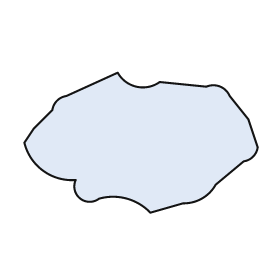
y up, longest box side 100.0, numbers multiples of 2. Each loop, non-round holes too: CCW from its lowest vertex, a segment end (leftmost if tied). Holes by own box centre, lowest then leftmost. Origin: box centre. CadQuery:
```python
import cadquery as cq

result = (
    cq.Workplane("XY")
    .moveTo(4.0, -30.0)
    .lineTo(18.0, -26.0)
    .threePointArc((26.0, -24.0), (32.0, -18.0))
    .lineTo(44.0, -8.0)
    .threePointArc((48.0, -6.0), (50.0, -2.0))
    .lineTo(46.0, 10.0)
    .lineTo(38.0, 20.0)
    .threePointArc((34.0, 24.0), (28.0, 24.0))
    .lineTo(8.0, 26.0)
    .threePointArc((-2.0, 24.0), (-10.0, 30.0))
    .lineTo(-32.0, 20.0)
    .threePointArc((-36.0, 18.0), (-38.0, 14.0))
    .lineTo(-46.0, 6.0)
    .lineTo(-50.0, 0.0)
    .threePointArc((-42.0, -12.0), (-28.0, -16.0))
    .threePointArc((-26.0, -24.0), (-18.0, -24.0))
    .threePointArc((-6.0, -24.0), (4.0, -30.0))
    .close()
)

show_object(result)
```